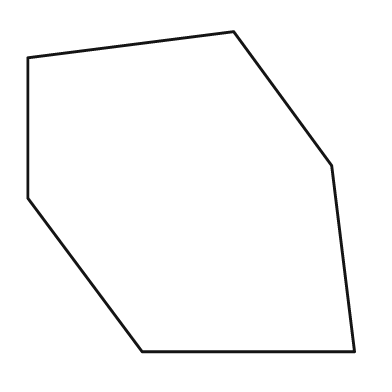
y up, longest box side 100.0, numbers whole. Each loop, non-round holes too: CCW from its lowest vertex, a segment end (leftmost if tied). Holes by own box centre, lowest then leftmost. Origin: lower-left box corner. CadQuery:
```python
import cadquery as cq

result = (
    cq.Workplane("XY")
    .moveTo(35.0, 0.0)
    .lineTo(100.0, 0.0)
    .lineTo(93.0, 57.0)
    .lineTo(63.0, 98.0)
    .lineTo(0.0, 90.0)
    .lineTo(0.0, 47.0)
    .close()
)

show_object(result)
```